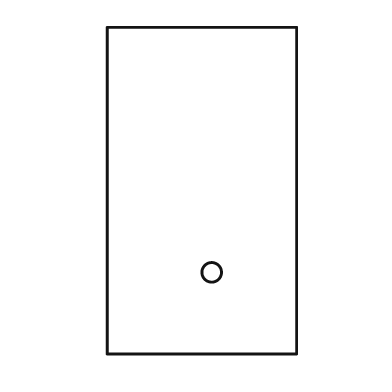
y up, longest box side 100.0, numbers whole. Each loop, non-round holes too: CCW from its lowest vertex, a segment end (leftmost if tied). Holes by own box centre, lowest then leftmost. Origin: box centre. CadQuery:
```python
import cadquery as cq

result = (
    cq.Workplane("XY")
    .moveTo(-29.0, -50.0)
    .lineTo(29.0, -50.0)
    .lineTo(29.0, 50.0)
    .lineTo(-29.0, 50.0)
    .close()
    .moveTo(3.0, -25.0)
    .circle(3.0)
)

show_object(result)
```